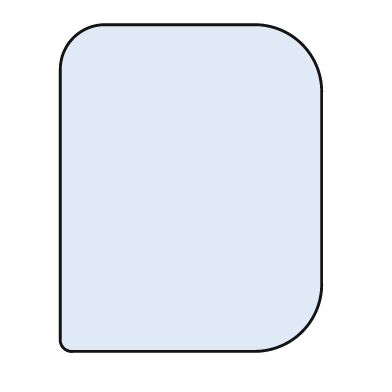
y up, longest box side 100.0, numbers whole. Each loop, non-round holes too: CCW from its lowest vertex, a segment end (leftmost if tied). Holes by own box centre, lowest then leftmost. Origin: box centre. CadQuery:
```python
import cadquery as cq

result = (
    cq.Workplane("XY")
    .moveTo(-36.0, -50.0)
    .lineTo(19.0, -50.0)
    .threePointArc((34.0, -44.0), (40.0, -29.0))
    .lineTo(40.0, 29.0)
    .threePointArc((34.0, 44.0), (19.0, 50.0))
    .lineTo(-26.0, 50.0)
    .threePointArc((-36.0, 46.0), (-40.0, 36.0))
    .lineTo(-40.0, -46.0)
    .threePointArc((-39.0, -49.0), (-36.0, -50.0))
    .close()
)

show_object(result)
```